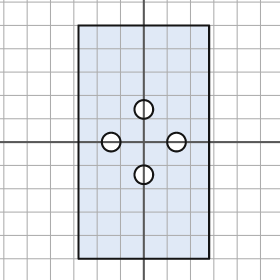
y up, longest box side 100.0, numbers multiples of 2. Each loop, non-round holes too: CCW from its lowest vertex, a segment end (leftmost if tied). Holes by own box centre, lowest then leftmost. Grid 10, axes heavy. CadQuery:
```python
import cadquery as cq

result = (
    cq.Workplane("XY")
    .moveTo(-28.0, -50.0)
    .lineTo(28.0, -50.0)
    .lineTo(28.0, 50.0)
    .lineTo(-28.0, 50.0)
    .close()
    .moveTo(0.0, -14.0)
    .circle(4.0)
    .moveTo(-14.0, 0.0)
    .circle(4.0)
    .moveTo(14.0, 0.0)
    .circle(4.0)
    .moveTo(0.0, 14.0)
    .circle(4.0)
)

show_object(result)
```